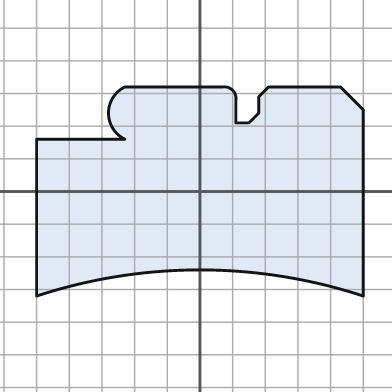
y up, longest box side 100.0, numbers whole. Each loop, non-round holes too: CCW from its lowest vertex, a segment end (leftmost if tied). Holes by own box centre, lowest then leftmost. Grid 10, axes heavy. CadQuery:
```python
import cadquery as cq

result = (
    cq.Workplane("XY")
    .moveTo(-50.0, -32.0)
    .threePointArc((0.0, -24.0), (50.0, -32.0))
    .lineTo(50.0, 25.0)
    .lineTo(43.0, 32.0)
    .lineTo(21.0, 32.0)
    .lineTo(18.0, 29.0)
    .lineTo(18.0, 24.0)
    .lineTo(15.0, 21.0)
    .lineTo(11.0, 21.0)
    .lineTo(11.0, 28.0)
    .threePointArc((10.0, 31.0), (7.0, 32.0))
    .lineTo(-23.0, 32.0)
    .threePointArc((-28.0, 24.0), (-23.0, 16.0))
    .lineTo(-50.0, 16.0)
    .close()
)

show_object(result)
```